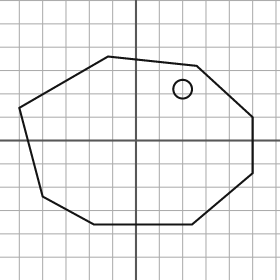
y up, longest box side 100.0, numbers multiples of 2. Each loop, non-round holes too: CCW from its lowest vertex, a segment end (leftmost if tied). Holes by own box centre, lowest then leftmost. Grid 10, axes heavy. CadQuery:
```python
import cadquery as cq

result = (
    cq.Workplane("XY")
    .moveTo(-18.0, -36.0)
    .lineTo(24.0, -36.0)
    .lineTo(50.0, -14.0)
    .lineTo(50.0, 10.0)
    .lineTo(26.0, 32.0)
    .lineTo(-12.0, 36.0)
    .lineTo(-50.0, 14.0)
    .lineTo(-40.0, -24.0)
    .close()
    .moveTo(20.0, 22.0)
    .circle(4.0)
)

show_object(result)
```